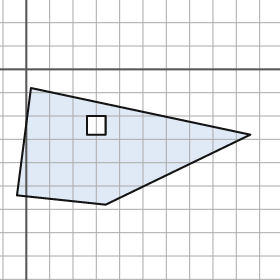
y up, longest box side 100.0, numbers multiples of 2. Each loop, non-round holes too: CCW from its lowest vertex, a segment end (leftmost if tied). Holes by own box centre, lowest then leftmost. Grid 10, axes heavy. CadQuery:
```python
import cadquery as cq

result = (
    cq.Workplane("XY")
    .moveTo(34.0, -58.0)
    .lineTo(96.0, -28.0)
    .lineTo(2.0, -8.0)
    .lineTo(-4.0, -54.0)
    .close()
    .moveTo(26.0, -28.0)
    .lineTo(34.0, -28.0)
    .lineTo(34.0, -20.0)
    .lineTo(26.0, -20.0)
    .close()
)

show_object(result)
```